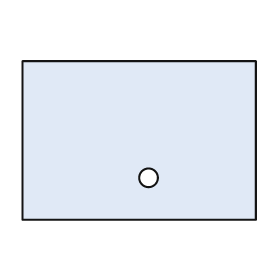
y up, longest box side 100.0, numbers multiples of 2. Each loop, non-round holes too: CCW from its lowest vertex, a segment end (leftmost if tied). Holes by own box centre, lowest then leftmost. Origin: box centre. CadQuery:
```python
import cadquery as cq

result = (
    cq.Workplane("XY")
    .moveTo(-50.0, -34.0)
    .lineTo(50.0, -34.0)
    .lineTo(50.0, 34.0)
    .lineTo(-50.0, 34.0)
    .close()
    .moveTo(4.0, -16.0)
    .circle(4.0)
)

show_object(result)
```